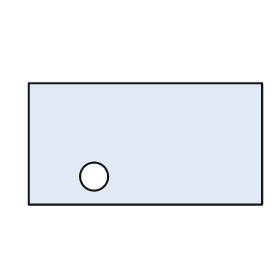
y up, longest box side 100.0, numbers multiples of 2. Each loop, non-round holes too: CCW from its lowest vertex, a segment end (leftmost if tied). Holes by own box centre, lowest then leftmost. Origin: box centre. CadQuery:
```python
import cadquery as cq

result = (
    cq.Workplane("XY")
    .moveTo(-50.0, -26.0)
    .lineTo(50.0, -26.0)
    .lineTo(50.0, 26.0)
    .lineTo(-50.0, 26.0)
    .close()
    .moveTo(-22.0, -14.0)
    .circle(6.0)
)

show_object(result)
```